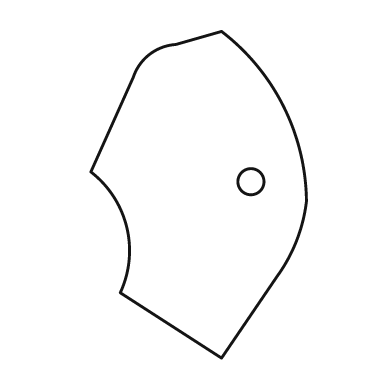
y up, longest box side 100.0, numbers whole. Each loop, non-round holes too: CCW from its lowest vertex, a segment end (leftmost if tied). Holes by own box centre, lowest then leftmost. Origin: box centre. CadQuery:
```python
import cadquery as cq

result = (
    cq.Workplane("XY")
    .moveTo(7.0, -50.0)
    .lineTo(24.0, -25.0)
    .threePointArc((30.0, -14.0), (33.0, -2.0))
    .threePointArc((26.0, 27.0), (7.0, 50.0))
    .lineTo(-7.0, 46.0)
    .threePointArc((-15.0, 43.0), (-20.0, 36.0))
    .lineTo(-33.0, 7.0)
    .threePointArc((-22.0, -10.0), (-24.0, -30.0))
    .close()
    .moveTo(16.0, 4.0)
    .circle(4.0)
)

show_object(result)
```